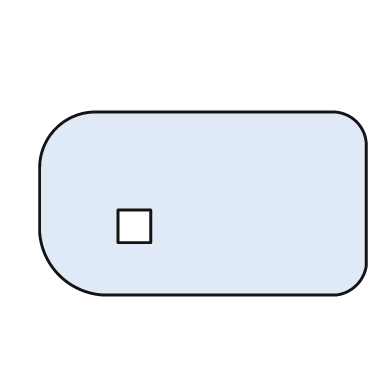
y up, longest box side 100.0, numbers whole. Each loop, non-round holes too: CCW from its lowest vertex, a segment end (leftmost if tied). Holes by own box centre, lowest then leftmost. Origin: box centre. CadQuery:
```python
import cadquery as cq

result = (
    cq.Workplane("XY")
    .moveTo(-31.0, -28.0)
    .lineTo(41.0, -28.0)
    .threePointArc((47.0, -25.0), (50.0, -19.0))
    .lineTo(50.0, 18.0)
    .threePointArc((47.0, 25.0), (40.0, 28.0))
    .lineTo(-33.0, 28.0)
    .threePointArc((-45.0, 23.0), (-50.0, 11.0))
    .lineTo(-50.0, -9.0)
    .threePointArc((-44.0, -22.0), (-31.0, -28.0))
    .close()
    .moveTo(-26.0, -12.0)
    .lineTo(-16.0, -12.0)
    .lineTo(-16.0, -2.0)
    .lineTo(-26.0, -2.0)
    .close()
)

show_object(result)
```